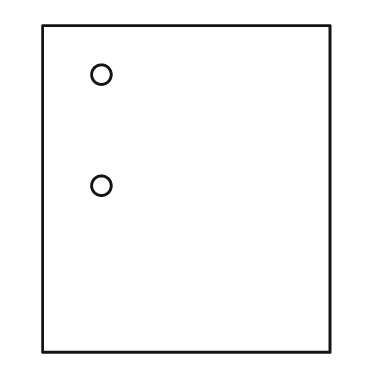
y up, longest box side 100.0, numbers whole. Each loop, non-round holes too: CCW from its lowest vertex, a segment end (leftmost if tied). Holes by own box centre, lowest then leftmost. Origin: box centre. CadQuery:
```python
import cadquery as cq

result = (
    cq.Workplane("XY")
    .moveTo(-44.0, -50.0)
    .lineTo(44.0, -50.0)
    .lineTo(44.0, 50.0)
    .lineTo(-44.0, 50.0)
    .close()
    .moveTo(-26.0, 1.0)
    .circle(3.0)
    .moveTo(-26.0, 35.0)
    .circle(3.0)
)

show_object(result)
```